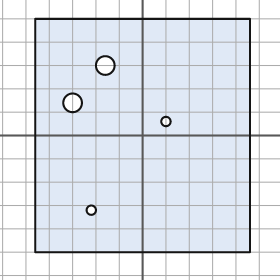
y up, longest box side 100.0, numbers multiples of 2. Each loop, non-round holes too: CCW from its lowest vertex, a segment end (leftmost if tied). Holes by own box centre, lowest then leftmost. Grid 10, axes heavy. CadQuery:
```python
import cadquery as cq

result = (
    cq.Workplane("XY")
    .moveTo(-46.0, -50.0)
    .lineTo(46.0, -50.0)
    .lineTo(46.0, 50.0)
    .lineTo(-46.0, 50.0)
    .close()
    .moveTo(-22.0, -32.0)
    .circle(2.0)
    .moveTo(10.0, 6.0)
    .circle(2.0)
    .moveTo(-30.0, 14.0)
    .circle(4.0)
    .moveTo(-16.0, 30.0)
    .circle(4.0)
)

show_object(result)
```